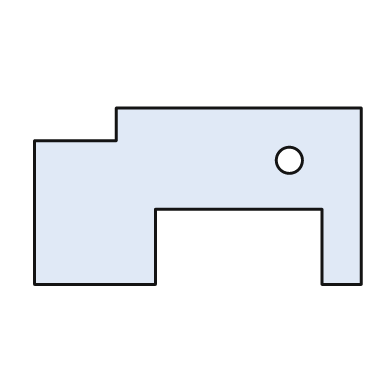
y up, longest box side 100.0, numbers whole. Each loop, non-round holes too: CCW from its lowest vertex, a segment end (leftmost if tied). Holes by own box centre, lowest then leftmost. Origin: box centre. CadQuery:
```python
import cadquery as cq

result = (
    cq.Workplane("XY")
    .moveTo(-50.0, -27.0)
    .lineTo(-13.0, -27.0)
    .lineTo(-13.0, -4.0)
    .lineTo(38.0, -4.0)
    .lineTo(38.0, -27.0)
    .lineTo(50.0, -27.0)
    .lineTo(50.0, 27.0)
    .lineTo(-25.0, 27.0)
    .lineTo(-25.0, 17.0)
    .lineTo(-50.0, 17.0)
    .close()
    .moveTo(28.0, 11.0)
    .circle(4.0)
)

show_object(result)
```